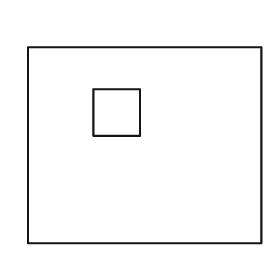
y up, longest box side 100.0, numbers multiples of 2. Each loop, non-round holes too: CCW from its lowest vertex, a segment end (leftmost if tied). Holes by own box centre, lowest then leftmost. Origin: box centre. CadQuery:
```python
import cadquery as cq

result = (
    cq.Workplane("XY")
    .moveTo(-50.0, -42.0)
    .lineTo(50.0, -42.0)
    .lineTo(50.0, 42.0)
    .lineTo(-50.0, 42.0)
    .close()
    .moveTo(-22.0, 4.0)
    .lineTo(-2.0, 4.0)
    .lineTo(-2.0, 24.0)
    .lineTo(-22.0, 24.0)
    .close()
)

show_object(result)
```